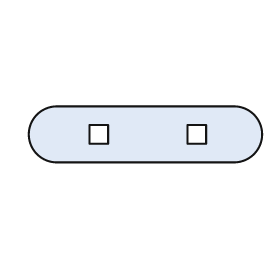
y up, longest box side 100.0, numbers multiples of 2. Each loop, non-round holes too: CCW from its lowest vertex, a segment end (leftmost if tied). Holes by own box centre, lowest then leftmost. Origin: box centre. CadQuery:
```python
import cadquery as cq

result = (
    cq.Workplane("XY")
    .moveTo(-38.0, -12.0)
    .lineTo(38.0, -12.0)
    .threePointArc((50.0, 0.0), (38.0, 12.0))
    .lineTo(-38.0, 12.0)
    .threePointArc((-50.0, 0.0), (-38.0, -12.0))
    .close()
    .moveTo(-24.0, -4.0)
    .lineTo(-16.0, -4.0)
    .lineTo(-16.0, 4.0)
    .lineTo(-24.0, 4.0)
    .close()
    .moveTo(18.0, -4.0)
    .lineTo(26.0, -4.0)
    .lineTo(26.0, 4.0)
    .lineTo(18.0, 4.0)
    .close()
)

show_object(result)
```